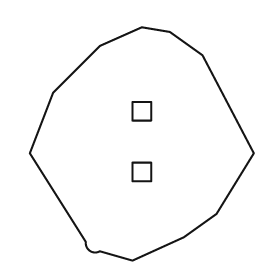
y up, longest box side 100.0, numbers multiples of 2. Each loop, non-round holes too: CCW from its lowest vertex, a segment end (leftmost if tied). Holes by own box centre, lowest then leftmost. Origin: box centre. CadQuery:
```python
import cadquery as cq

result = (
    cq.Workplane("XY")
    .moveTo(-4.0, -50.0)
    .lineTo(18.0, -40.0)
    .lineTo(32.0, -30.0)
    .lineTo(48.0, -4.0)
    .lineTo(26.0, 38.0)
    .lineTo(12.0, 48.0)
    .lineTo(0.0, 50.0)
    .lineTo(-18.0, 42.0)
    .lineTo(-38.0, 22.0)
    .lineTo(-48.0, -4.0)
    .lineTo(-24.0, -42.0)
    .threePointArc((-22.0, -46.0), (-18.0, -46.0))
    .close()
    .moveTo(-4.0, -16.0)
    .lineTo(4.0, -16.0)
    .lineTo(4.0, -8.0)
    .lineTo(-4.0, -8.0)
    .close()
    .moveTo(-4.0, 10.0)
    .lineTo(4.0, 10.0)
    .lineTo(4.0, 18.0)
    .lineTo(-4.0, 18.0)
    .close()
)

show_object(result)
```